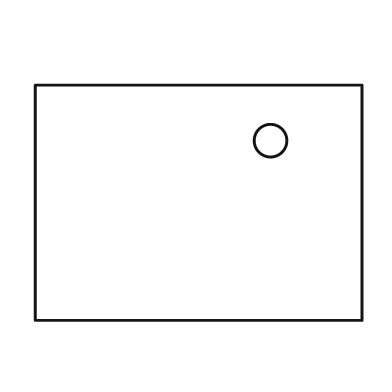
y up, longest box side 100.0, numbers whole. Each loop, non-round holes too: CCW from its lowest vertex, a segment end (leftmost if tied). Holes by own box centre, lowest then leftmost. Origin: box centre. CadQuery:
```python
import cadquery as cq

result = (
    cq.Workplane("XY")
    .moveTo(-50.0, -36.0)
    .lineTo(50.0, -36.0)
    .lineTo(50.0, 36.0)
    .lineTo(-50.0, 36.0)
    .close()
    .moveTo(22.0, 19.0)
    .circle(5.0)
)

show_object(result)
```